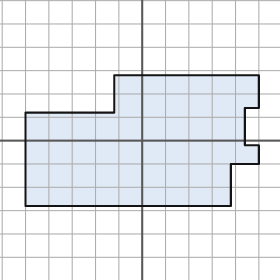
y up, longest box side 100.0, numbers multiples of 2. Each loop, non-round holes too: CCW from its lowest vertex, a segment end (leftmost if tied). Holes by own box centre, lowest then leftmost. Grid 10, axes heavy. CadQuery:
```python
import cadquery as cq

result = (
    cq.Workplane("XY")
    .moveTo(-50.0, -28.0)
    .lineTo(38.0, -28.0)
    .lineTo(38.0, -10.0)
    .lineTo(50.0, -10.0)
    .lineTo(50.0, -2.0)
    .lineTo(44.0, -2.0)
    .lineTo(44.0, 14.0)
    .lineTo(50.0, 14.0)
    .lineTo(50.0, 28.0)
    .lineTo(-12.0, 28.0)
    .lineTo(-12.0, 12.0)
    .lineTo(-50.0, 12.0)
    .close()
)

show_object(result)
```